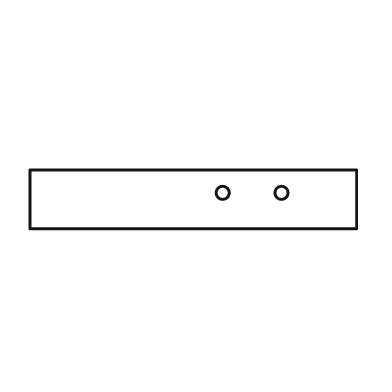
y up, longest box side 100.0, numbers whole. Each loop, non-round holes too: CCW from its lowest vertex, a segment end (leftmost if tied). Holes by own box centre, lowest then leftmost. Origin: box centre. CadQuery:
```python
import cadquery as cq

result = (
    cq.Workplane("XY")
    .moveTo(-50.0, -9.0)
    .lineTo(50.0, -9.0)
    .lineTo(50.0, 9.0)
    .lineTo(-50.0, 9.0)
    .close()
    .moveTo(9.0, 2.0)
    .circle(2.0)
    .moveTo(27.0, 2.0)
    .circle(2.0)
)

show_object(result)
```